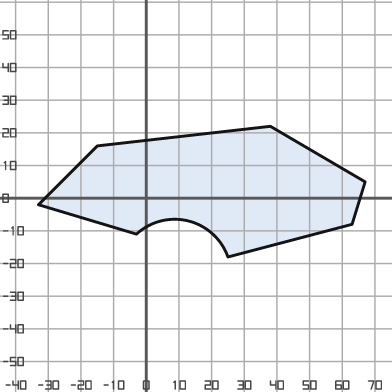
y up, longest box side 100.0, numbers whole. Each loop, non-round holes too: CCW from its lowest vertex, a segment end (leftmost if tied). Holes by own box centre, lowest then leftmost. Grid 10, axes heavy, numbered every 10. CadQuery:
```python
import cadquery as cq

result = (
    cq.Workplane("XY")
    .moveTo(25.0, -18.0)
    .lineTo(63.0, -8.0)
    .lineTo(67.0, 5.0)
    .lineTo(38.0, 22.0)
    .lineTo(-15.0, 16.0)
    .lineTo(-33.0, -2.0)
    .lineTo(-3.0, -11.0)
    .threePointArc((13.0, -7.0), (25.0, -18.0))
    .close()
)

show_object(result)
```